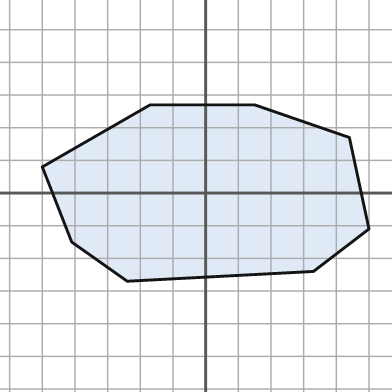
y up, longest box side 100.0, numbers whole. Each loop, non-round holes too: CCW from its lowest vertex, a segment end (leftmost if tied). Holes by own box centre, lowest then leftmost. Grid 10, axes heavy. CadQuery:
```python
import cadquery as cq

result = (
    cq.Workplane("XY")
    .moveTo(-24.0, -27.0)
    .lineTo(33.0, -24.0)
    .lineTo(50.0, -11.0)
    .lineTo(44.0, 17.0)
    .lineTo(15.0, 27.0)
    .lineTo(-17.0, 27.0)
    .lineTo(-50.0, 8.0)
    .lineTo(-41.0, -15.0)
    .close()
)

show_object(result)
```